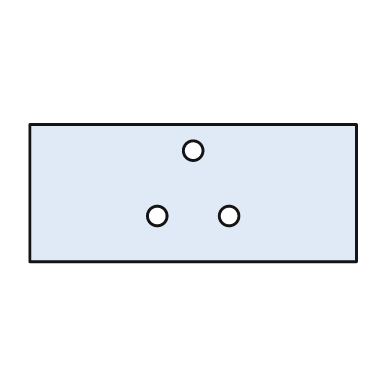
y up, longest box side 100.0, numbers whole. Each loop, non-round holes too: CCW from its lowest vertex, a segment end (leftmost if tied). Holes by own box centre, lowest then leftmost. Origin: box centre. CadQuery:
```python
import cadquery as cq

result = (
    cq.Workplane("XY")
    .moveTo(-50.0, -21.0)
    .lineTo(50.0, -21.0)
    .lineTo(50.0, 21.0)
    .lineTo(-50.0, 21.0)
    .close()
    .moveTo(-11.0, -7.0)
    .circle(3.0)
    .moveTo(11.0, -7.0)
    .circle(3.0)
    .moveTo(0.0, 13.0)
    .circle(3.0)
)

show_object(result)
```